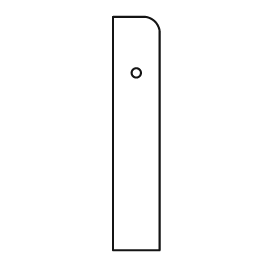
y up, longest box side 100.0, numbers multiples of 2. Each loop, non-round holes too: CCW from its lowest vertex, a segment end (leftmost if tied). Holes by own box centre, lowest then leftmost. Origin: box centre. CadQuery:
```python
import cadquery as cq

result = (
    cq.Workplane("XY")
    .moveTo(-10.0, -50.0)
    .lineTo(10.0, -50.0)
    .lineTo(10.0, 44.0)
    .threePointArc((8.0, 48.0), (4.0, 50.0))
    .lineTo(-10.0, 50.0)
    .close()
    .moveTo(0.0, 26.0)
    .circle(2.0)
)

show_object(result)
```